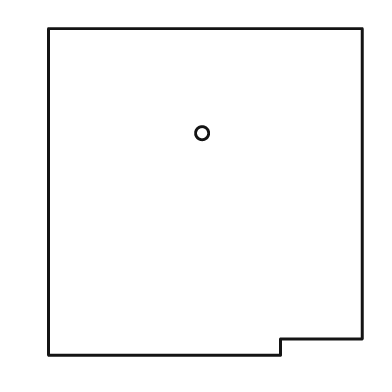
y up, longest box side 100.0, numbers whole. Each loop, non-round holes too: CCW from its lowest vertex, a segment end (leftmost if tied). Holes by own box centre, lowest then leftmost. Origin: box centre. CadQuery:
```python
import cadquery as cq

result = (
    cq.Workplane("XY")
    .moveTo(-48.0, -50.0)
    .lineTo(23.0, -50.0)
    .lineTo(23.0, -45.0)
    .lineTo(48.0, -45.0)
    .lineTo(48.0, 50.0)
    .lineTo(-48.0, 50.0)
    .close()
    .moveTo(-1.0, 18.0)
    .circle(2.0)
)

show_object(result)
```